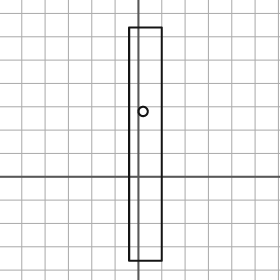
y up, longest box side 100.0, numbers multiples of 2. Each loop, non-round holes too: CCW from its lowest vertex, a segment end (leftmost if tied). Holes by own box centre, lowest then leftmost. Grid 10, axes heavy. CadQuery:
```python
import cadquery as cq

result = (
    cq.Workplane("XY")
    .moveTo(-4.0, -36.0)
    .lineTo(10.0, -36.0)
    .lineTo(10.0, 64.0)
    .lineTo(-4.0, 64.0)
    .close()
    .moveTo(2.0, 28.0)
    .circle(2.0)
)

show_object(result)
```